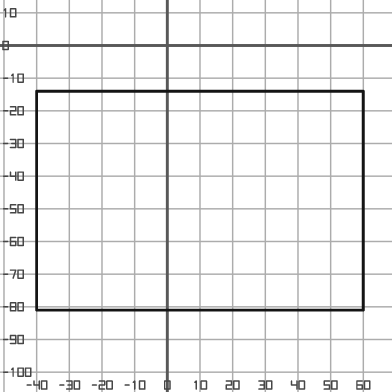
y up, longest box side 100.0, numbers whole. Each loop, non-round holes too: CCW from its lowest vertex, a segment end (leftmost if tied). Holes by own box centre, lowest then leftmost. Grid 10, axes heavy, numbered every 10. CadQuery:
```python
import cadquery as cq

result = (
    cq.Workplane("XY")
    .moveTo(-40.0, -81.0)
    .lineTo(60.0, -81.0)
    .lineTo(60.0, -14.0)
    .lineTo(-40.0, -14.0)
    .close()
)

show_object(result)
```